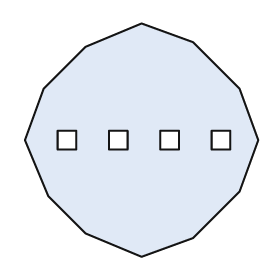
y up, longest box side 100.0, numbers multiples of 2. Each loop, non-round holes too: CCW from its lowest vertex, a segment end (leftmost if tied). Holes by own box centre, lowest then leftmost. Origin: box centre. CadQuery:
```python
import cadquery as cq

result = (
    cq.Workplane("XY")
    .moveTo(0.0, -50.0)
    .lineTo(22.0, -42.0)
    .lineTo(42.0, -22.0)
    .lineTo(50.0, 0.0)
    .lineTo(42.0, 22.0)
    .lineTo(22.0, 42.0)
    .lineTo(0.0, 50.0)
    .lineTo(-24.0, 40.0)
    .lineTo(-42.0, 22.0)
    .lineTo(-50.0, 0.0)
    .lineTo(-40.0, -24.0)
    .lineTo(-24.0, -40.0)
    .close()
    .moveTo(-36.0, -4.0)
    .lineTo(-28.0, -4.0)
    .lineTo(-28.0, 4.0)
    .lineTo(-36.0, 4.0)
    .close()
    .moveTo(-14.0, -4.0)
    .lineTo(-6.0, -4.0)
    .lineTo(-6.0, 4.0)
    .lineTo(-14.0, 4.0)
    .close()
    .moveTo(8.0, -4.0)
    .lineTo(16.0, -4.0)
    .lineTo(16.0, 4.0)
    .lineTo(8.0, 4.0)
    .close()
    .moveTo(30.0, -4.0)
    .lineTo(38.0, -4.0)
    .lineTo(38.0, 4.0)
    .lineTo(30.0, 4.0)
    .close()
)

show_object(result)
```